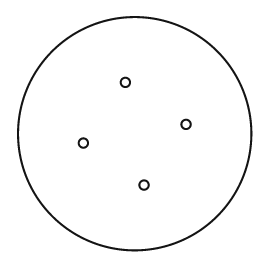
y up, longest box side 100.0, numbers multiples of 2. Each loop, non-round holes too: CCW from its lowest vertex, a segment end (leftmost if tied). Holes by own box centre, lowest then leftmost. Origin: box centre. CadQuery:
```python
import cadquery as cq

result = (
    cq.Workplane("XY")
    .moveTo(0.0, 0.0)
    .circle(50.0)
    .moveTo(4.0, -22.0)
    .circle(2.0)
    .moveTo(-22.0, -4.0)
    .circle(2.0)
    .moveTo(22.0, 4.0)
    .circle(2.0)
    .moveTo(-4.0, 22.0)
    .circle(2.0)
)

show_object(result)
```